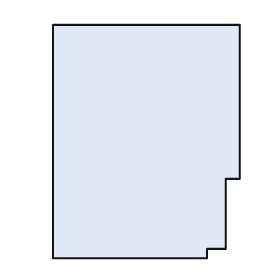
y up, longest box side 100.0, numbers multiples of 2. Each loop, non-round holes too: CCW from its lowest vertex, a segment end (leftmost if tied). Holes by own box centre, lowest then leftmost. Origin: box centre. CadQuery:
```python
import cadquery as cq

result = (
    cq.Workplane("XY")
    .moveTo(-40.0, -50.0)
    .lineTo(26.0, -50.0)
    .lineTo(26.0, -46.0)
    .lineTo(34.0, -46.0)
    .lineTo(34.0, -16.0)
    .lineTo(40.0, -16.0)
    .lineTo(40.0, 50.0)
    .lineTo(-40.0, 50.0)
    .close()
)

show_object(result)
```